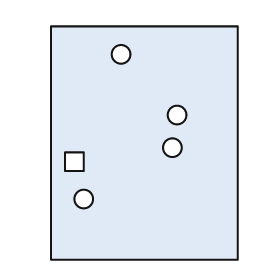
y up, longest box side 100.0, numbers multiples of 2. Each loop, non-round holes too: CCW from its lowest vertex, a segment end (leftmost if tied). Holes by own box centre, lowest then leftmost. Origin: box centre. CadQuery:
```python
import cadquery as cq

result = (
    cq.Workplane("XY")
    .moveTo(-40.0, -50.0)
    .lineTo(40.0, -50.0)
    .lineTo(40.0, 50.0)
    .lineTo(-40.0, 50.0)
    .close()
    .moveTo(-26.0, -24.0)
    .circle(4.0)
    .moveTo(-34.0, -12.0)
    .lineTo(-26.0, -12.0)
    .lineTo(-26.0, -4.0)
    .lineTo(-34.0, -4.0)
    .close()
    .moveTo(12.0, -2.0)
    .circle(4.0)
    .moveTo(14.0, 12.0)
    .circle(4.0)
    .moveTo(-10.0, 38.0)
    .circle(4.0)
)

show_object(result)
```